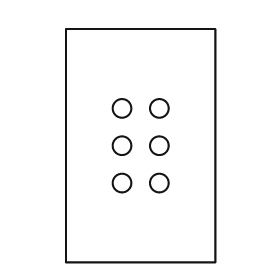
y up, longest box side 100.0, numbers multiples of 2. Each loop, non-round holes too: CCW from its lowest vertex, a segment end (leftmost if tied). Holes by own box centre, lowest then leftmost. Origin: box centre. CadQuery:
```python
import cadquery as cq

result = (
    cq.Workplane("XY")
    .moveTo(-32.0, -50.0)
    .lineTo(32.0, -50.0)
    .lineTo(32.0, 50.0)
    .lineTo(-32.0, 50.0)
    .close()
    .moveTo(-8.0, -16.0)
    .circle(4.0)
    .moveTo(8.0, -16.0)
    .circle(4.0)
    .moveTo(-8.0, 0.0)
    .circle(4.0)
    .moveTo(8.0, 0.0)
    .circle(4.0)
    .moveTo(-8.0, 16.0)
    .circle(4.0)
    .moveTo(8.0, 16.0)
    .circle(4.0)
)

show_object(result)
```